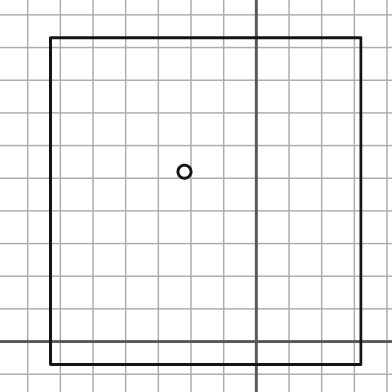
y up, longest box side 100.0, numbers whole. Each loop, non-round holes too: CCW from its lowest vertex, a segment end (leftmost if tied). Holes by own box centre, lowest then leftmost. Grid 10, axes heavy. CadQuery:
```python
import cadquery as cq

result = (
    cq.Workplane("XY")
    .moveTo(-63.0, -7.0)
    .lineTo(32.0, -7.0)
    .lineTo(32.0, 93.0)
    .lineTo(-63.0, 93.0)
    .close()
    .moveTo(-22.0, 52.0)
    .circle(2.0)
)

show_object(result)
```